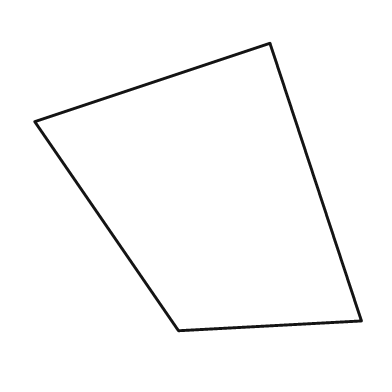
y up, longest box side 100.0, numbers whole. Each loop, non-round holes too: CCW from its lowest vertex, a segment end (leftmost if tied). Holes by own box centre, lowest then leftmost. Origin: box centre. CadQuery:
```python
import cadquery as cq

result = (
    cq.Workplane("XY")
    .moveTo(-6.0, -44.0)
    .lineTo(50.0, -41.0)
    .lineTo(22.0, 44.0)
    .lineTo(-50.0, 20.0)
    .close()
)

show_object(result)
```